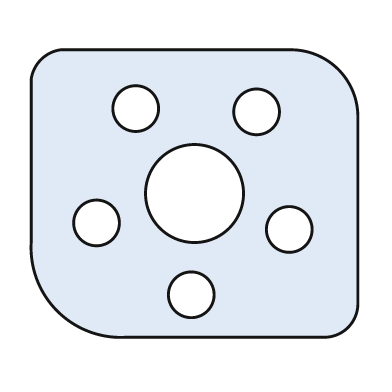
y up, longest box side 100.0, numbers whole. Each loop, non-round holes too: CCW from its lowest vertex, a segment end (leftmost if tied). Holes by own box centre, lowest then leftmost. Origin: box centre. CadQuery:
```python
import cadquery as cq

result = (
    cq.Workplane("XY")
    .moveTo(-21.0, -44.0)
    .lineTo(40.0, -44.0)
    .threePointArc((47.0, -41.0), (50.0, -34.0))
    .lineTo(50.0, 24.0)
    .threePointArc((44.0, 38.0), (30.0, 44.0))
    .lineTo(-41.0, 44.0)
    .threePointArc((-47.0, 41.0), (-50.0, 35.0))
    .lineTo(-50.0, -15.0)
    .threePointArc((-42.0, -36.0), (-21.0, -44.0))
    .close()
    .moveTo(-1.0, -31.0)
    .circle(7.0)
    .moveTo(29.0, -11.0)
    .circle(7.0)
    .moveTo(-30.0, -9.0)
    .circle(7.0)
    .moveTo(0.0, 0.0)
    .circle(15.0)
    .moveTo(19.0, 25.0)
    .circle(7.0)
    .moveTo(-18.0, 26.0)
    .circle(7.0)
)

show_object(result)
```